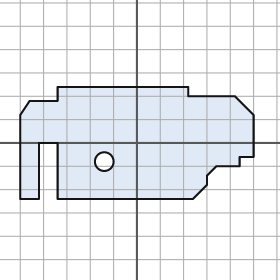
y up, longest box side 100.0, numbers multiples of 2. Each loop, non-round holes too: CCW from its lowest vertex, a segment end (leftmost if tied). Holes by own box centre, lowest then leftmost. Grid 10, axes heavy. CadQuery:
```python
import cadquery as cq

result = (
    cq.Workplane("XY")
    .moveTo(-50.0, -24.0)
    .lineTo(-42.0, -24.0)
    .lineTo(-42.0, 0.0)
    .lineTo(-34.0, 0.0)
    .lineTo(-34.0, -24.0)
    .lineTo(24.0, -24.0)
    .lineTo(30.0, -18.0)
    .lineTo(30.0, -14.0)
    .lineTo(34.0, -10.0)
    .lineTo(44.0, -10.0)
    .lineTo(44.0, -6.0)
    .lineTo(50.0, -6.0)
    .lineTo(50.0, 12.0)
    .lineTo(42.0, 20.0)
    .lineTo(22.0, 20.0)
    .lineTo(22.0, 24.0)
    .lineTo(-34.0, 24.0)
    .lineTo(-34.0, 18.0)
    .lineTo(-46.0, 18.0)
    .lineTo(-50.0, 12.0)
    .close()
    .moveTo(-14.0, -8.0)
    .circle(4.0)
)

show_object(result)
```